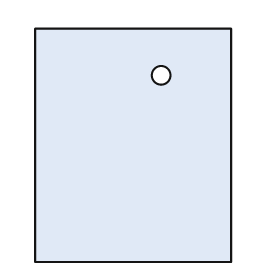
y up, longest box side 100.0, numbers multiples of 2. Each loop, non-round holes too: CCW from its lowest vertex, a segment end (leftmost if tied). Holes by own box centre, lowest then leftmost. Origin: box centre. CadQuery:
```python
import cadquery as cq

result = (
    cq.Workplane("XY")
    .moveTo(-42.0, -50.0)
    .lineTo(42.0, -50.0)
    .lineTo(42.0, 50.0)
    .lineTo(-42.0, 50.0)
    .close()
    .moveTo(12.0, 30.0)
    .circle(4.0)
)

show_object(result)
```